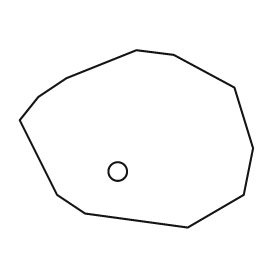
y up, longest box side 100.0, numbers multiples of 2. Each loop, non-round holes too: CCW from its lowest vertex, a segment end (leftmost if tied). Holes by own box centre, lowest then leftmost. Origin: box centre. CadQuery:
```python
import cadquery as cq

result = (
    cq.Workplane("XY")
    .moveTo(22.0, -38.0)
    .lineTo(46.0, -24.0)
    .lineTo(50.0, -4.0)
    .lineTo(42.0, 22.0)
    .lineTo(16.0, 36.0)
    .lineTo(0.0, 38.0)
    .lineTo(-30.0, 26.0)
    .lineTo(-42.0, 18.0)
    .lineTo(-50.0, 8.0)
    .lineTo(-34.0, -24.0)
    .lineTo(-22.0, -32.0)
    .close()
    .moveTo(-8.0, -14.0)
    .circle(4.0)
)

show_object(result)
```